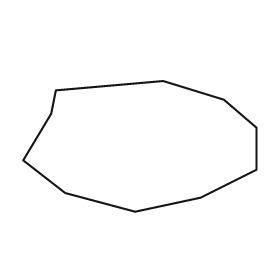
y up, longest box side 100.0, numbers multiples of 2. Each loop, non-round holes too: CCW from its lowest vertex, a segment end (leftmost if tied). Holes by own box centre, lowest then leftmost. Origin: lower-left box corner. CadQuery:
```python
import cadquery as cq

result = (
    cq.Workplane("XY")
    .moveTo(48.0, 0.0)
    .lineTo(76.0, 6.0)
    .lineTo(100.0, 18.0)
    .lineTo(100.0, 36.0)
    .lineTo(86.0, 48.0)
    .lineTo(60.0, 56.0)
    .lineTo(14.0, 52.0)
    .lineTo(12.0, 42.0)
    .lineTo(0.0, 22.0)
    .lineTo(18.0, 8.0)
    .close()
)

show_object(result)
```